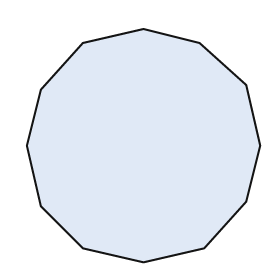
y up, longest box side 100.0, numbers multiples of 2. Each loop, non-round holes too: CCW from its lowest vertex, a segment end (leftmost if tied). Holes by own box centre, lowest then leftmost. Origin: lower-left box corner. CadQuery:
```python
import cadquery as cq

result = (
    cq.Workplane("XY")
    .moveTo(50.0, 0.0)
    .lineTo(76.0, 6.0)
    .lineTo(94.0, 26.0)
    .lineTo(100.0, 50.0)
    .lineTo(94.0, 76.0)
    .lineTo(74.0, 94.0)
    .lineTo(50.0, 100.0)
    .lineTo(24.0, 94.0)
    .lineTo(6.0, 74.0)
    .lineTo(0.0, 50.0)
    .lineTo(6.0, 24.0)
    .lineTo(24.0, 6.0)
    .close()
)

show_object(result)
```